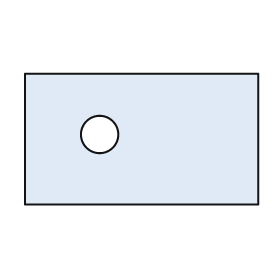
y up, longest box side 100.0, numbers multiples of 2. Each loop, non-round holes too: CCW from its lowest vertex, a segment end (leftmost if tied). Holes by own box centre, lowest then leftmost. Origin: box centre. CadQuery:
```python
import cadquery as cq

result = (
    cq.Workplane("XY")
    .moveTo(-50.0, -28.0)
    .lineTo(50.0, -28.0)
    .lineTo(50.0, 28.0)
    .lineTo(-50.0, 28.0)
    .close()
    .moveTo(-18.0, 2.0)
    .circle(8.0)
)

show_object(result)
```